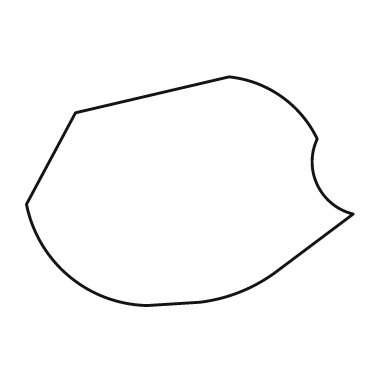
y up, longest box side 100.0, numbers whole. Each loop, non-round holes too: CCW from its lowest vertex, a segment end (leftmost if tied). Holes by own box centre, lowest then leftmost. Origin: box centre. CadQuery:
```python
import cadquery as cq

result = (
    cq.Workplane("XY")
    .moveTo(-13.0, -35.0)
    .lineTo(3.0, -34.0)
    .threePointArc((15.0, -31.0), (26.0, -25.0))
    .lineTo(50.0, -7.0)
    .threePointArc((39.0, 2.0), (39.0, 16.0))
    .threePointArc((28.0, 29.0), (12.0, 35.0))
    .lineTo(-35.0, 24.0)
    .lineTo(-50.0, -4.0)
    .threePointArc((-37.0, -26.0), (-13.0, -35.0))
    .close()
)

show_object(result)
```